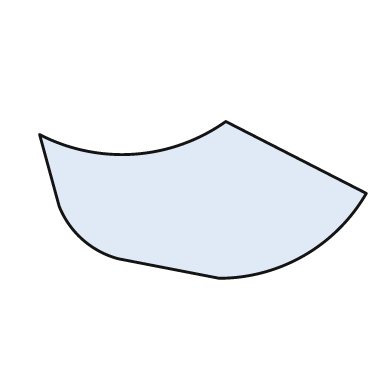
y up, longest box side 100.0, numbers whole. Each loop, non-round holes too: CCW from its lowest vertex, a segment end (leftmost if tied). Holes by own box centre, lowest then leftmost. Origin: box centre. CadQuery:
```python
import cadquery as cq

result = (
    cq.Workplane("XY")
    .moveTo(5.0, -24.0)
    .threePointArc((31.0, -17.0), (50.0, 2.0))
    .lineTo(7.0, 24.0)
    .threePointArc((-21.0, 14.0), (-50.0, 20.0))
    .lineTo(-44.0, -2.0)
    .threePointArc((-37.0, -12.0), (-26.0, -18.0))
    .close()
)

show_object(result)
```